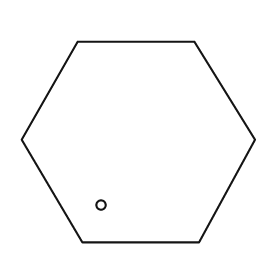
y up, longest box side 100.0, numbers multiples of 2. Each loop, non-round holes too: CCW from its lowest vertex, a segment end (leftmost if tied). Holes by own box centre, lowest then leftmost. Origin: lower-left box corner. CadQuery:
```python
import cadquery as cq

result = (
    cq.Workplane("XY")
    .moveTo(26.0, 0.0)
    .lineTo(76.0, 0.0)
    .lineTo(100.0, 44.0)
    .lineTo(74.0, 86.0)
    .lineTo(24.0, 86.0)
    .lineTo(0.0, 44.0)
    .close()
    .moveTo(34.0, 16.0)
    .circle(2.0)
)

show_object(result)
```